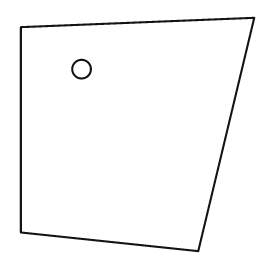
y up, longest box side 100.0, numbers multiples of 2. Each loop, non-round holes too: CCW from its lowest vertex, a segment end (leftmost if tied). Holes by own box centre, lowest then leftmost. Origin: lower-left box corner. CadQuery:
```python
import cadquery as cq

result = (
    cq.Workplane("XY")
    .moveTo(76.0, 0.0)
    .lineTo(100.0, 100.0)
    .lineTo(0.0, 96.0)
    .lineTo(0.0, 8.0)
    .close()
    .moveTo(26.0, 78.0)
    .circle(4.0)
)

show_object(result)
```